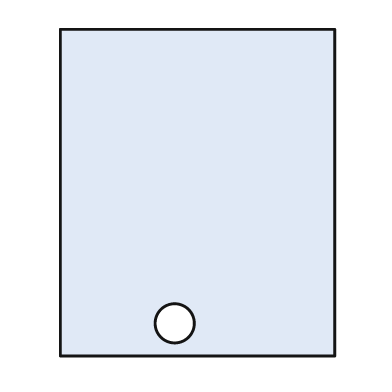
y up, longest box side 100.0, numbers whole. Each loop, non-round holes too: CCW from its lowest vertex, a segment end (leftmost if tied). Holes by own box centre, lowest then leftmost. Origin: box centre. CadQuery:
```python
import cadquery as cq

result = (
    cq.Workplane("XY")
    .moveTo(-42.0, -50.0)
    .lineTo(42.0, -50.0)
    .lineTo(42.0, 50.0)
    .lineTo(-42.0, 50.0)
    .close()
    .moveTo(-7.0, -40.0)
    .circle(6.0)
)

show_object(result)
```